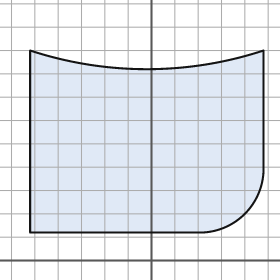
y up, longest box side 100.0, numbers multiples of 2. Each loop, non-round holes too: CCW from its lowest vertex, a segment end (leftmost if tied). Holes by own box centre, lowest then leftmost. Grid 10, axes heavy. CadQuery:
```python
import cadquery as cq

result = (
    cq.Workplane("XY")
    .moveTo(-52.0, 12.0)
    .lineTo(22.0, 12.0)
    .threePointArc((40.0, 20.0), (48.0, 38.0))
    .lineTo(48.0, 90.0)
    .threePointArc((-2.0, 82.0), (-52.0, 90.0))
    .close()
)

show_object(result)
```